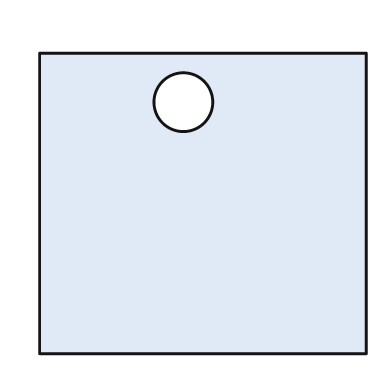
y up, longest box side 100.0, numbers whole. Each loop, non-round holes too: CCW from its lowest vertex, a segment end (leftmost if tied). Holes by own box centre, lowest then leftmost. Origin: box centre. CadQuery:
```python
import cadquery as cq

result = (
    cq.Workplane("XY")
    .moveTo(-50.0, -46.0)
    .lineTo(50.0, -46.0)
    .lineTo(50.0, 46.0)
    .lineTo(-50.0, 46.0)
    .close()
    .moveTo(-6.0, 31.0)
    .circle(9.0)
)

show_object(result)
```